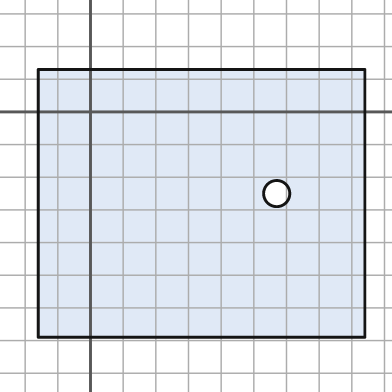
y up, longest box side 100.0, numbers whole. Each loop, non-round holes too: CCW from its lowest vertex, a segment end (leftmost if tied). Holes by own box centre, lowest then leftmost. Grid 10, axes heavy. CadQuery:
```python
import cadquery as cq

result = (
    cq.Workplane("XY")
    .moveTo(-16.0, -69.0)
    .lineTo(84.0, -69.0)
    .lineTo(84.0, 13.0)
    .lineTo(-16.0, 13.0)
    .close()
    .moveTo(57.0, -25.0)
    .circle(4.0)
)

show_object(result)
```